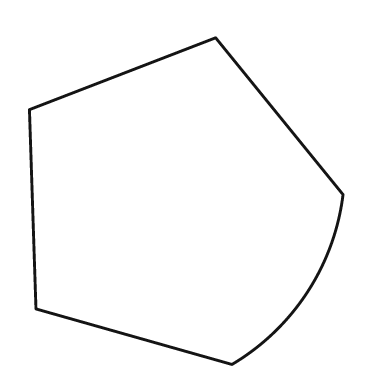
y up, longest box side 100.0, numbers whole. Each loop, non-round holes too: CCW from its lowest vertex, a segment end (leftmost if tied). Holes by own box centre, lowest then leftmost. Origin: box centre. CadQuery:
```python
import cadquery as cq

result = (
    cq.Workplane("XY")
    .moveTo(14.0, -50.0)
    .threePointArc((37.0, -28.0), (48.0, 2.0))
    .lineTo(9.0, 50.0)
    .lineTo(-48.0, 28.0)
    .lineTo(-46.0, -33.0)
    .close()
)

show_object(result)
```